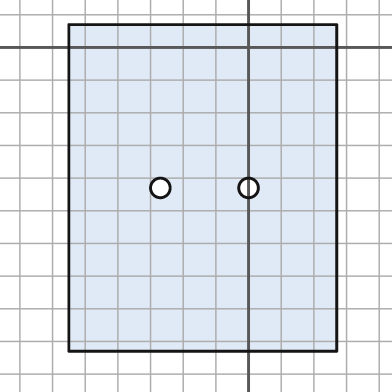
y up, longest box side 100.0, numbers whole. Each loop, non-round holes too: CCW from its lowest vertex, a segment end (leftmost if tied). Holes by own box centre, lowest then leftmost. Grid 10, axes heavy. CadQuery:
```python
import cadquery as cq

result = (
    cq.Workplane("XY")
    .moveTo(-55.0, -93.0)
    .lineTo(27.0, -93.0)
    .lineTo(27.0, 7.0)
    .lineTo(-55.0, 7.0)
    .close()
    .moveTo(-27.0, -43.0)
    .circle(3.0)
    .moveTo(0.0, -43.0)
    .circle(3.0)
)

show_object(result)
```